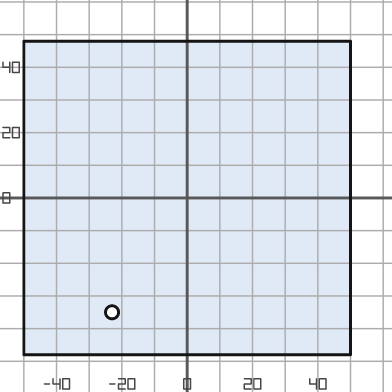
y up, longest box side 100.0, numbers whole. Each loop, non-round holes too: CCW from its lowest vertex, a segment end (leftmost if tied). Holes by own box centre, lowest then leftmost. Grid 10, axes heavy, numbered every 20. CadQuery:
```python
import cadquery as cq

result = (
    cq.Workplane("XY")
    .moveTo(-50.0, -48.0)
    .lineTo(50.0, -48.0)
    .lineTo(50.0, 48.0)
    .lineTo(-50.0, 48.0)
    .close()
    .moveTo(-23.0, -35.0)
    .circle(2.0)
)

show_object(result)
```